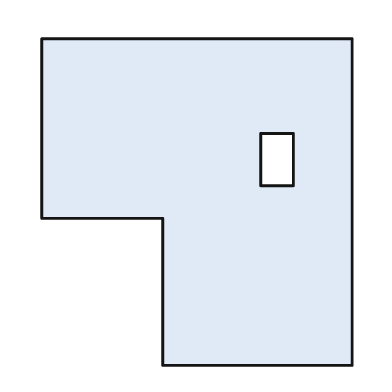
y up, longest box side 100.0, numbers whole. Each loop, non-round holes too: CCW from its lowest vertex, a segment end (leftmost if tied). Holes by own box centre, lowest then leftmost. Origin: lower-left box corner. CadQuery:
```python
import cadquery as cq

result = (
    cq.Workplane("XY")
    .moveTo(37.0, 0.0)
    .lineTo(95.0, 0.0)
    .lineTo(95.0, 100.0)
    .lineTo(0.0, 100.0)
    .lineTo(0.0, 45.0)
    .lineTo(37.0, 45.0)
    .close()
    .moveTo(67.0, 55.0)
    .lineTo(77.0, 55.0)
    .lineTo(77.0, 71.0)
    .lineTo(67.0, 71.0)
    .close()
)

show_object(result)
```